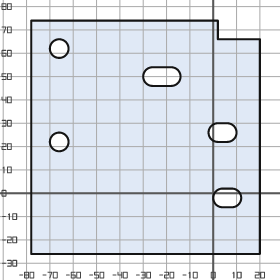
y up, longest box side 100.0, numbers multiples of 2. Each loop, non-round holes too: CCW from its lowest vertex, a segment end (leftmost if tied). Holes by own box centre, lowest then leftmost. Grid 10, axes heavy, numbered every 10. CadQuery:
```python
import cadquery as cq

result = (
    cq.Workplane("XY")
    .moveTo(-78.0, -26.0)
    .lineTo(20.0, -26.0)
    .lineTo(20.0, 66.0)
    .lineTo(2.0, 66.0)
    .lineTo(2.0, 74.0)
    .lineTo(-78.0, 74.0)
    .close()
    .moveTo(4.0, -6.0)
    .lineTo(8.0, -6.0)
    .threePointArc((12.0, -2.0), (8.0, 2.0))
    .lineTo(4.0, 2.0)
    .threePointArc((0.0, -2.0), (4.0, -6.0))
    .close()
    .moveTo(-66.0, 22.0)
    .circle(4.0)
    .moveTo(2.0, 22.0)
    .lineTo(6.0, 22.0)
    .threePointArc((10.0, 26.0), (6.0, 30.0))
    .lineTo(2.0, 30.0)
    .threePointArc((-2.0, 26.0), (2.0, 22.0))
    .close()
    .moveTo(-26.0, 46.0)
    .lineTo(-18.0, 46.0)
    .threePointArc((-14.0, 50.0), (-18.0, 54.0))
    .lineTo(-26.0, 54.0)
    .threePointArc((-30.0, 50.0), (-26.0, 46.0))
    .close()
    .moveTo(-66.0, 62.0)
    .circle(4.0)
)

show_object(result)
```